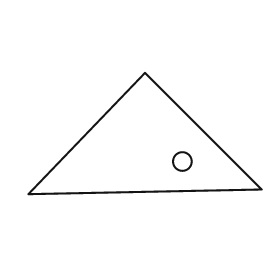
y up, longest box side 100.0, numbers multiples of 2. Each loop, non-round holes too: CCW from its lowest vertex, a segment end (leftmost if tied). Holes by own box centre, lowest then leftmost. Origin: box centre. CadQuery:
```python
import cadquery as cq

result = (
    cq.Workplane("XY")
    .moveTo(-50.0, -26.0)
    .lineTo(50.0, -24.0)
    .lineTo(0.0, 26.0)
    .close()
    .moveTo(16.0, -12.0)
    .circle(4.0)
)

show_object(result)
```